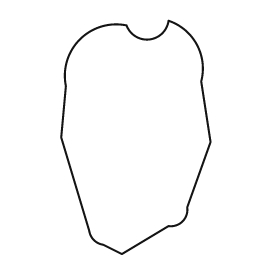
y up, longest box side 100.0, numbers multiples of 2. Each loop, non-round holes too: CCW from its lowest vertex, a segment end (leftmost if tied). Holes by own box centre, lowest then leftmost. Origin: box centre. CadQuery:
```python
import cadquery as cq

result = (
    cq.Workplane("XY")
    .moveTo(-6.0, -50.0)
    .lineTo(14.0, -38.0)
    .threePointArc((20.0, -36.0), (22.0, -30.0))
    .lineTo(32.0, -2.0)
    .lineTo(28.0, 24.0)
    .threePointArc((26.0, 40.0), (14.0, 50.0))
    .threePointArc((6.0, 42.0), (-4.0, 48.0))
    .threePointArc((-24.0, 42.0), (-30.0, 22.0))
    .lineTo(-32.0, 0.0)
    .lineTo(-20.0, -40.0)
    .threePointArc((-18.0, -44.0), (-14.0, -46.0))
    .close()
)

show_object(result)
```